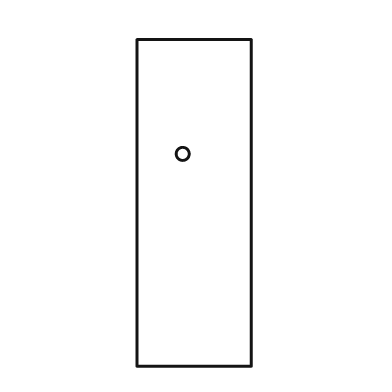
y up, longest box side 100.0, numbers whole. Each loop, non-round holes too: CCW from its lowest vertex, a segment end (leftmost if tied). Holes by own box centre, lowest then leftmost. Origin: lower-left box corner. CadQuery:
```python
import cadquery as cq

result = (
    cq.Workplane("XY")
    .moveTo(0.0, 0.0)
    .lineTo(35.0, 0.0)
    .lineTo(35.0, 100.0)
    .lineTo(0.0, 100.0)
    .close()
    .moveTo(14.0, 65.0)
    .circle(2.0)
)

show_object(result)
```